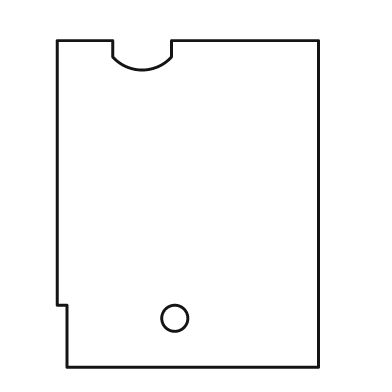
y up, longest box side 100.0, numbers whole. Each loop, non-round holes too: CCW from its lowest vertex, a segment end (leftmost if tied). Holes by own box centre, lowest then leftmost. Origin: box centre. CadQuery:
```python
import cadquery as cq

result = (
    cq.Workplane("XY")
    .moveTo(-37.0, -50.0)
    .lineTo(40.0, -50.0)
    .lineTo(40.0, 50.0)
    .lineTo(-5.0, 50.0)
    .lineTo(-5.0, 45.0)
    .threePointArc((-14.0, 41.0), (-23.0, 45.0))
    .lineTo(-23.0, 50.0)
    .lineTo(-40.0, 50.0)
    .lineTo(-40.0, -31.0)
    .lineTo(-37.0, -31.0)
    .close()
    .moveTo(-4.0, -35.0)
    .circle(4.0)
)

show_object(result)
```